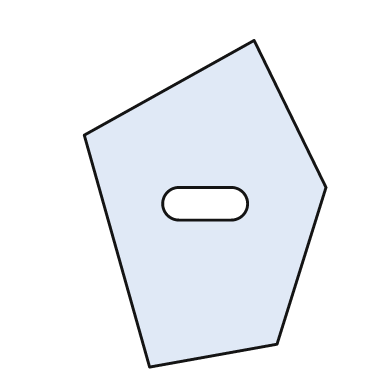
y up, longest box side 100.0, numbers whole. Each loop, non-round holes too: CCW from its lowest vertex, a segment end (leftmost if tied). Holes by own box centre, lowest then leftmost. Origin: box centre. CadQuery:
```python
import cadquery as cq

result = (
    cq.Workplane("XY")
    .moveTo(-17.0, -50.0)
    .lineTo(22.0, -43.0)
    .lineTo(37.0, 5.0)
    .lineTo(15.0, 50.0)
    .lineTo(-37.0, 21.0)
    .close()
    .moveTo(-8.0, -5.0)
    .lineTo(8.0, -5.0)
    .threePointArc((13.0, 0.0), (8.0, 5.0))
    .lineTo(-8.0, 5.0)
    .threePointArc((-13.0, 0.0), (-8.0, -5.0))
    .close()
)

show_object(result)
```